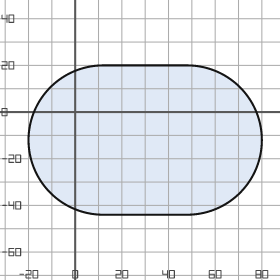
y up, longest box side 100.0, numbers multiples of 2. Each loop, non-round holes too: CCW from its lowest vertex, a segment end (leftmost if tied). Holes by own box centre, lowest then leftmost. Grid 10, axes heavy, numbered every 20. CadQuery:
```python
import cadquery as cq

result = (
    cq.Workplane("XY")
    .moveTo(12.0, -44.0)
    .lineTo(48.0, -44.0)
    .threePointArc((80.0, -12.0), (48.0, 20.0))
    .lineTo(12.0, 20.0)
    .threePointArc((-20.0, -12.0), (12.0, -44.0))
    .close()
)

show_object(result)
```